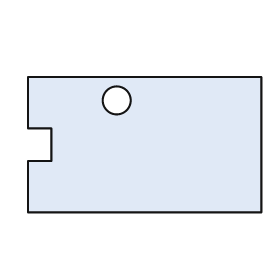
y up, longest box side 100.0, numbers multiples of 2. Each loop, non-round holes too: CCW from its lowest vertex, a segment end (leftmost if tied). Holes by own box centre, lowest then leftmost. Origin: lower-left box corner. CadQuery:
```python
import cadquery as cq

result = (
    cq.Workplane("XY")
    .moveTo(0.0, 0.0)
    .lineTo(100.0, 0.0)
    .lineTo(100.0, 58.0)
    .lineTo(0.0, 58.0)
    .lineTo(0.0, 36.0)
    .lineTo(10.0, 36.0)
    .lineTo(10.0, 22.0)
    .lineTo(0.0, 22.0)
    .close()
    .moveTo(38.0, 48.0)
    .circle(6.0)
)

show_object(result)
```